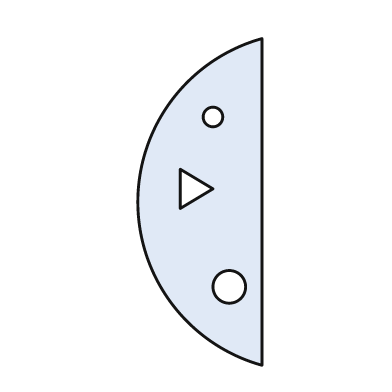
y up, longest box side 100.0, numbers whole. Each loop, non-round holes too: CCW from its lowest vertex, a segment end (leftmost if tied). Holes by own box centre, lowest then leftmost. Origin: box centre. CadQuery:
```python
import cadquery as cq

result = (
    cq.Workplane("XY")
    .moveTo(19.0, -50.0)
    .lineTo(19.0, 50.0)
    .threePointArc((-19.0, 0.0), (19.0, -50.0))
    .close()
    .moveTo(9.0, -26.0)
    .circle(5.0)
    .moveTo(-6.0, -2.0)
    .lineTo(4.0, 4.0)
    .lineTo(-6.0, 10.0)
    .close()
    .moveTo(4.0, 26.0)
    .circle(3.0)
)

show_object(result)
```